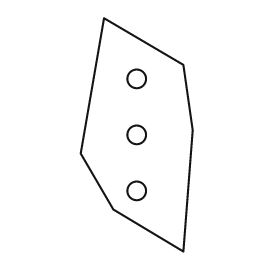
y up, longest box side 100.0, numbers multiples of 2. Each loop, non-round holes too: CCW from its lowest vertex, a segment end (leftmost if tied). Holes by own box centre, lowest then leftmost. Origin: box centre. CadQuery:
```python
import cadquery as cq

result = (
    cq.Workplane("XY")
    .moveTo(20.0, -50.0)
    .lineTo(24.0, 2.0)
    .lineTo(20.0, 30.0)
    .lineTo(-14.0, 50.0)
    .lineTo(-24.0, -8.0)
    .lineTo(-10.0, -32.0)
    .close()
    .moveTo(0.0, -24.0)
    .circle(4.0)
    .moveTo(0.0, 0.0)
    .circle(4.0)
    .moveTo(0.0, 24.0)
    .circle(4.0)
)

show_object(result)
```